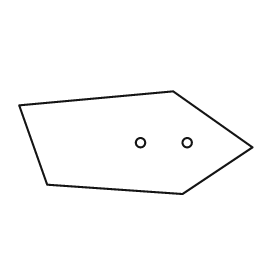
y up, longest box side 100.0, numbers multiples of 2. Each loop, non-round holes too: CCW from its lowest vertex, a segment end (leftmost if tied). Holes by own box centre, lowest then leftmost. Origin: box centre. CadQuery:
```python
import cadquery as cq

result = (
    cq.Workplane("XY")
    .moveTo(20.0, -22.0)
    .lineTo(50.0, -2.0)
    .lineTo(16.0, 22.0)
    .lineTo(-50.0, 16.0)
    .lineTo(-38.0, -18.0)
    .close()
    .moveTo(2.0, 0.0)
    .circle(2.0)
    .moveTo(22.0, 0.0)
    .circle(2.0)
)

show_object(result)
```